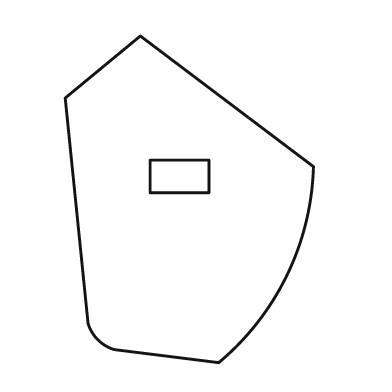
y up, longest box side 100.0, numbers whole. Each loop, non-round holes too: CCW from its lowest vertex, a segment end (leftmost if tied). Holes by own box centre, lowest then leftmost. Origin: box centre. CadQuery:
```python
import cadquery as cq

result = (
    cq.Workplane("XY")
    .moveTo(9.0, -50.0)
    .threePointArc((30.0, -23.0), (38.0, 10.0))
    .lineTo(-15.0, 50.0)
    .lineTo(-38.0, 31.0)
    .lineTo(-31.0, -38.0)
    .threePointArc((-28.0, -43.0), (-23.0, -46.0))
    .close()
    .moveTo(-12.0, 2.0)
    .lineTo(6.0, 2.0)
    .lineTo(6.0, 12.0)
    .lineTo(-12.0, 12.0)
    .close()
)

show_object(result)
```